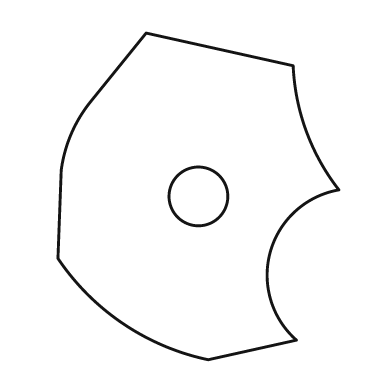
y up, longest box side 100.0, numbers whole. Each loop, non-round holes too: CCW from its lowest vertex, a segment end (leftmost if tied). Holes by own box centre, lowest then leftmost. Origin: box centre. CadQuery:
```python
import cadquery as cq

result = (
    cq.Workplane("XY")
    .moveTo(3.0, -50.0)
    .lineTo(30.0, -44.0)
    .threePointArc((22.0, -17.0), (43.0, 2.0))
    .threePointArc((33.0, 20.0), (29.0, 40.0))
    .lineTo(-16.0, 50.0)
    .lineTo(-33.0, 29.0)
    .threePointArc((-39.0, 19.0), (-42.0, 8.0))
    .lineTo(-43.0, -19.0)
    .threePointArc((-23.0, -39.0), (3.0, -50.0))
    .close()
    .moveTo(0.0, 0.0)
    .circle(9.0)
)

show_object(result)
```